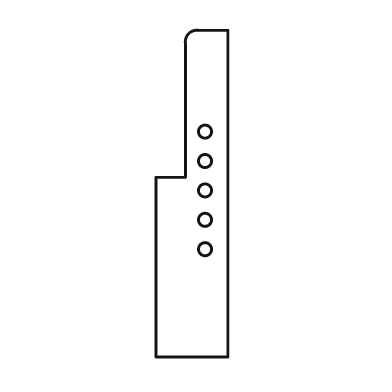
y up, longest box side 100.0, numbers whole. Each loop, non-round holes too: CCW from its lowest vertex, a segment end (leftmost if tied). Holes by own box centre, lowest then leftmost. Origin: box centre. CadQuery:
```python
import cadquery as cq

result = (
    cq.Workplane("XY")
    .moveTo(-11.0, -50.0)
    .lineTo(11.0, -50.0)
    .lineTo(11.0, 50.0)
    .lineTo(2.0, 50.0)
    .threePointArc((-1.0, 49.0), (-2.0, 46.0))
    .lineTo(-2.0, 5.0)
    .lineTo(-11.0, 5.0)
    .close()
    .moveTo(4.0, -17.0)
    .circle(2.0)
    .moveTo(4.0, -8.0)
    .circle(2.0)
    .moveTo(4.0, 1.0)
    .circle(2.0)
    .moveTo(4.0, 10.0)
    .circle(2.0)
    .moveTo(4.0, 19.0)
    .circle(2.0)
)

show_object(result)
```